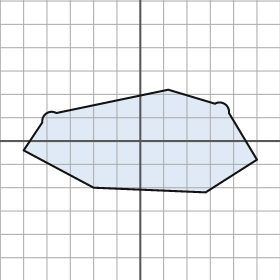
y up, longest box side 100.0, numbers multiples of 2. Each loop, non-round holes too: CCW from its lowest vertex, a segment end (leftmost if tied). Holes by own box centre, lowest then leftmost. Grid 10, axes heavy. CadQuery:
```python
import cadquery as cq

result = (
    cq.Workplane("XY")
    .moveTo(28.0, -22.0)
    .lineTo(50.0, -8.0)
    .lineTo(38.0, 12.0)
    .threePointArc((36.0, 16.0), (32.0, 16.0))
    .lineTo(12.0, 22.0)
    .lineTo(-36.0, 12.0)
    .threePointArc((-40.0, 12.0), (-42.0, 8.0))
    .lineTo(-50.0, -4.0)
    .lineTo(-20.0, -20.0)
    .close()
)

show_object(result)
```